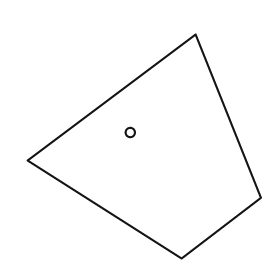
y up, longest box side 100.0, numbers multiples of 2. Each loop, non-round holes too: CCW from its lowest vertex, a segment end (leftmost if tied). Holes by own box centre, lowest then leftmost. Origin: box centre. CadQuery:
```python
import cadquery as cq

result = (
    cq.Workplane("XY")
    .moveTo(16.0, -48.0)
    .lineTo(50.0, -22.0)
    .lineTo(22.0, 48.0)
    .lineTo(-50.0, -6.0)
    .close()
    .moveTo(-6.0, 6.0)
    .circle(2.0)
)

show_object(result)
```